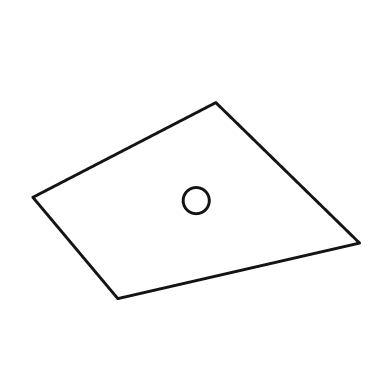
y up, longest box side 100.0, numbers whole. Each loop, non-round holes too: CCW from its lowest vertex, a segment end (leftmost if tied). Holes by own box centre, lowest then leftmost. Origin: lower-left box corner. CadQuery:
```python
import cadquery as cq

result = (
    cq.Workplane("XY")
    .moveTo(26.0, 0.0)
    .lineTo(100.0, 17.0)
    .lineTo(56.0, 60.0)
    .lineTo(0.0, 31.0)
    .close()
    .moveTo(50.0, 30.0)
    .circle(4.0)
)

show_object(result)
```